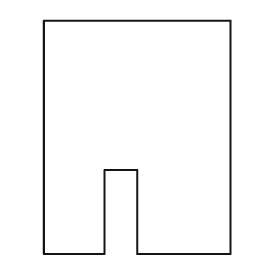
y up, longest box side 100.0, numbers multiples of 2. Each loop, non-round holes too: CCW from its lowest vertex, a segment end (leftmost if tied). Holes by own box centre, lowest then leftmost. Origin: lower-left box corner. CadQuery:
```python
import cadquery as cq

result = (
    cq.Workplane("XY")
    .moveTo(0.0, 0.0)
    .lineTo(26.0, 0.0)
    .lineTo(26.0, 36.0)
    .lineTo(40.0, 36.0)
    .lineTo(40.0, 0.0)
    .lineTo(80.0, 0.0)
    .lineTo(80.0, 100.0)
    .lineTo(0.0, 100.0)
    .close()
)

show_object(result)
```